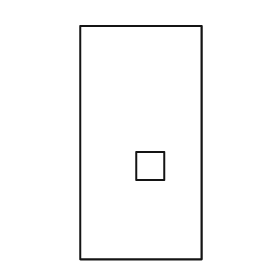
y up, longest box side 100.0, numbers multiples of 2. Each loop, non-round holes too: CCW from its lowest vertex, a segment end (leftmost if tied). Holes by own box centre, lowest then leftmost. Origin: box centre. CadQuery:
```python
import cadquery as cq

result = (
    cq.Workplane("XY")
    .moveTo(-26.0, -50.0)
    .lineTo(26.0, -50.0)
    .lineTo(26.0, 50.0)
    .lineTo(-26.0, 50.0)
    .close()
    .moveTo(-2.0, -16.0)
    .lineTo(10.0, -16.0)
    .lineTo(10.0, -4.0)
    .lineTo(-2.0, -4.0)
    .close()
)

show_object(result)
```